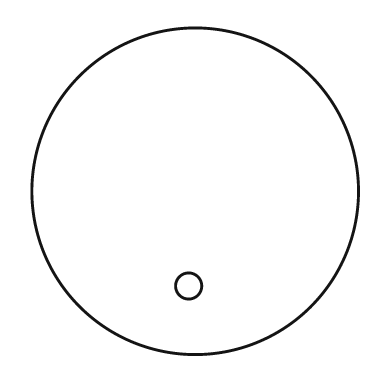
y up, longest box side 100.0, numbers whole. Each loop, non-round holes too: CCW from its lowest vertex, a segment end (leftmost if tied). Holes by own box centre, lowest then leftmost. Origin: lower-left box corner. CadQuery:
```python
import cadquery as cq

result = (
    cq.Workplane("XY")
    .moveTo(50.0, 50.0)
    .circle(50.0)
    .moveTo(48.0, 21.0)
    .circle(4.0)
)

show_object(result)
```